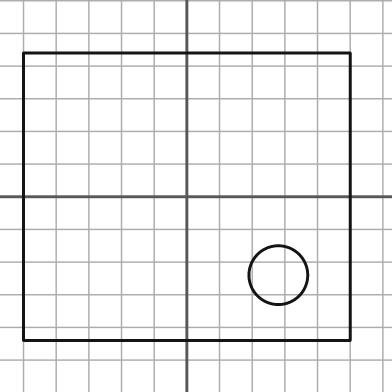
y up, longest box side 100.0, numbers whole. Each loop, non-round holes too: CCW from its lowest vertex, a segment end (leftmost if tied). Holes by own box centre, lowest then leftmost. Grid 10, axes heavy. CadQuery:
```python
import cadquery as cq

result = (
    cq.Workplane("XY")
    .moveTo(-50.0, -44.0)
    .lineTo(50.0, -44.0)
    .lineTo(50.0, 44.0)
    .lineTo(-50.0, 44.0)
    .close()
    .moveTo(28.0, -24.0)
    .circle(9.0)
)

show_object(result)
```